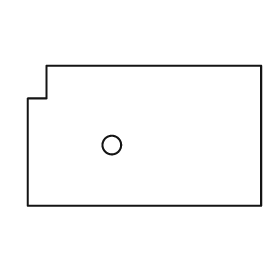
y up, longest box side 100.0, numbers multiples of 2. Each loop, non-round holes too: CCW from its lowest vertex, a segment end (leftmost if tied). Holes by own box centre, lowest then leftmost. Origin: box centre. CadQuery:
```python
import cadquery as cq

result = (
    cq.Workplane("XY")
    .moveTo(-50.0, -30.0)
    .lineTo(50.0, -30.0)
    .lineTo(50.0, 30.0)
    .lineTo(-42.0, 30.0)
    .lineTo(-42.0, 16.0)
    .lineTo(-50.0, 16.0)
    .close()
    .moveTo(-14.0, -4.0)
    .circle(4.0)
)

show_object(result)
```